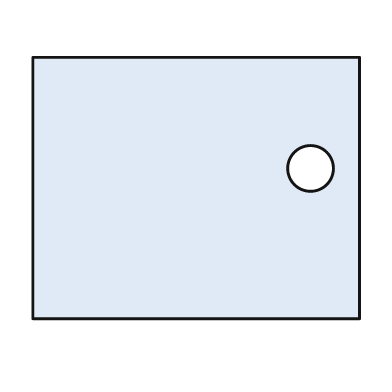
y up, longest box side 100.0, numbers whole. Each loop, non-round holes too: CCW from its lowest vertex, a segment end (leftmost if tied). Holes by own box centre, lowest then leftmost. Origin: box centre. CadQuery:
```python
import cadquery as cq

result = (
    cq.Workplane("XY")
    .moveTo(-50.0, -40.0)
    .lineTo(50.0, -40.0)
    .lineTo(50.0, 40.0)
    .lineTo(-50.0, 40.0)
    .close()
    .moveTo(35.0, 6.0)
    .circle(7.0)
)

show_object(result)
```